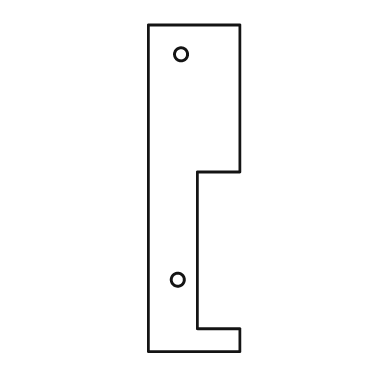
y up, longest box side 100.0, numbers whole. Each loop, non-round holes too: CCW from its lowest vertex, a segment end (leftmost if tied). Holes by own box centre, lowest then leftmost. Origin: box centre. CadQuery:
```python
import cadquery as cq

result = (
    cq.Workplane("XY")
    .moveTo(-14.0, -50.0)
    .lineTo(14.0, -50.0)
    .lineTo(14.0, -43.0)
    .lineTo(1.0, -43.0)
    .lineTo(1.0, 5.0)
    .lineTo(14.0, 5.0)
    .lineTo(14.0, 50.0)
    .lineTo(-14.0, 50.0)
    .close()
    .moveTo(-5.0, -28.0)
    .circle(2.0)
    .moveTo(-4.0, 41.0)
    .circle(2.0)
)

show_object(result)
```